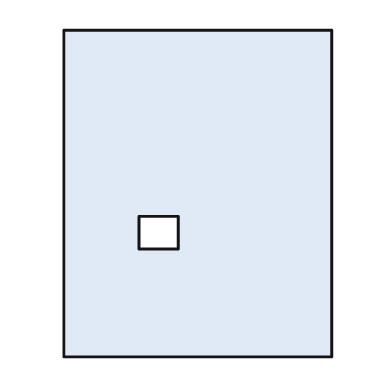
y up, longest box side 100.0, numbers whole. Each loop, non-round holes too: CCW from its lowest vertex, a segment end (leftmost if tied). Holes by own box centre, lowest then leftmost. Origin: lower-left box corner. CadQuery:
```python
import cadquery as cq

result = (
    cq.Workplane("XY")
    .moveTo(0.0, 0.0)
    .lineTo(82.0, 0.0)
    .lineTo(82.0, 100.0)
    .lineTo(0.0, 100.0)
    .close()
    .moveTo(23.0, 33.0)
    .lineTo(35.0, 33.0)
    .lineTo(35.0, 43.0)
    .lineTo(23.0, 43.0)
    .close()
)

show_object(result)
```